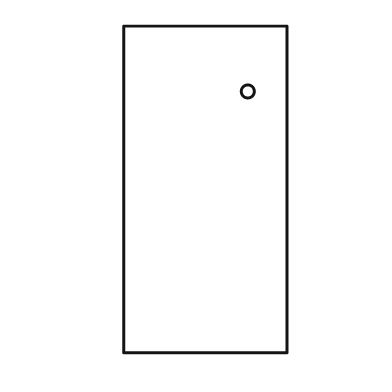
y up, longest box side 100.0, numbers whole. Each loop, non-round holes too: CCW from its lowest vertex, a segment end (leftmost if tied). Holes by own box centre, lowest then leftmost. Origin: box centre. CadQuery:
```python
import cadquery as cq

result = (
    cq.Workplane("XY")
    .moveTo(-25.0, -50.0)
    .lineTo(25.0, -50.0)
    .lineTo(25.0, 50.0)
    .lineTo(-25.0, 50.0)
    .close()
    .moveTo(13.0, 30.0)
    .circle(2.0)
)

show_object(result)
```